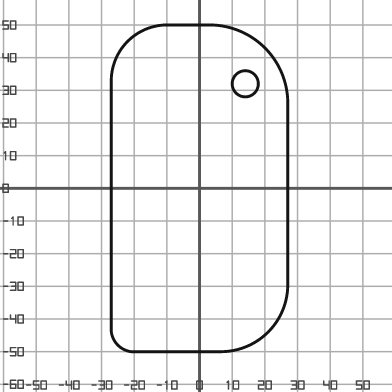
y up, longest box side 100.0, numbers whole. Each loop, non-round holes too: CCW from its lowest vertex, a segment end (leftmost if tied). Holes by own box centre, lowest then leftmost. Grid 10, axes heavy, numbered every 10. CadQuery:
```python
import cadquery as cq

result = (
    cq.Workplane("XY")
    .moveTo(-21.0, -50.0)
    .lineTo(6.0, -50.0)
    .threePointArc((21.0, -44.0), (27.0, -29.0))
    .lineTo(27.0, 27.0)
    .threePointArc((20.0, 43.0), (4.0, 50.0))
    .lineTo(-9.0, 50.0)
    .threePointArc((-22.0, 45.0), (-27.0, 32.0))
    .lineTo(-27.0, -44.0)
    .threePointArc((-25.0, -48.0), (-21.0, -50.0))
    .close()
    .moveTo(14.0, 32.0)
    .circle(4.0)
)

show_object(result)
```